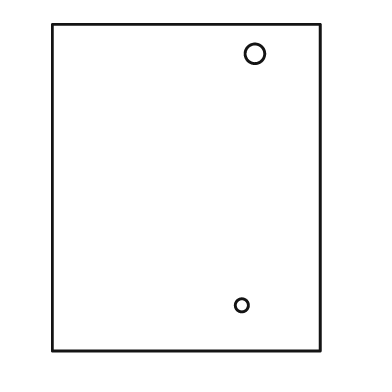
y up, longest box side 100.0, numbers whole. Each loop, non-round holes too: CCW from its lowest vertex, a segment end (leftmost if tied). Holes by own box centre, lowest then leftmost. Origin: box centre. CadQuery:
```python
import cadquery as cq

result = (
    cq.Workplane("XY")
    .moveTo(-41.0, -50.0)
    .lineTo(41.0, -50.0)
    .lineTo(41.0, 50.0)
    .lineTo(-41.0, 50.0)
    .close()
    .moveTo(17.0, -36.0)
    .circle(2.0)
    .moveTo(21.0, 41.0)
    .circle(3.0)
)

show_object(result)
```